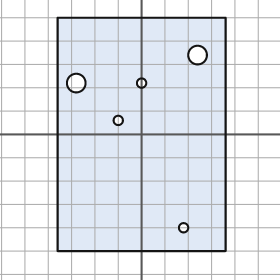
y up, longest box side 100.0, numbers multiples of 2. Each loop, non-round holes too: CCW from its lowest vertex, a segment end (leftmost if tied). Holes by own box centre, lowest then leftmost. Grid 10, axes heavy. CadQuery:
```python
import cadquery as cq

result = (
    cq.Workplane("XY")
    .moveTo(-36.0, -50.0)
    .lineTo(36.0, -50.0)
    .lineTo(36.0, 50.0)
    .lineTo(-36.0, 50.0)
    .close()
    .moveTo(18.0, -40.0)
    .circle(2.0)
    .moveTo(-10.0, 6.0)
    .circle(2.0)
    .moveTo(-28.0, 22.0)
    .circle(4.0)
    .moveTo(0.0, 22.0)
    .circle(2.0)
    .moveTo(24.0, 34.0)
    .circle(4.0)
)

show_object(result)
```